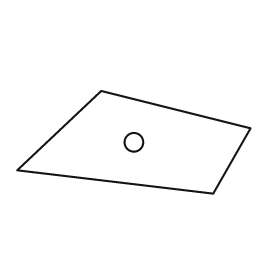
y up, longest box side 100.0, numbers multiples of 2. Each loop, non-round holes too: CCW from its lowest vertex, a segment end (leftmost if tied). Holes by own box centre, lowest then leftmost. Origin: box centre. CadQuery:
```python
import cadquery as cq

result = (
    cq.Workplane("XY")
    .moveTo(34.0, -22.0)
    .lineTo(50.0, 6.0)
    .lineTo(-14.0, 22.0)
    .lineTo(-50.0, -12.0)
    .close()
    .moveTo(0.0, 0.0)
    .circle(4.0)
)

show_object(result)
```